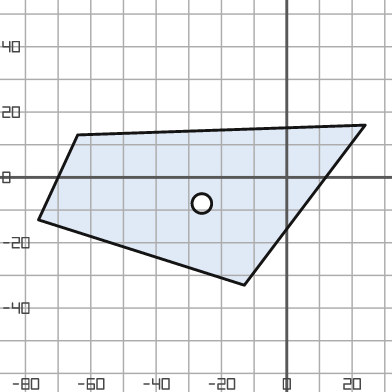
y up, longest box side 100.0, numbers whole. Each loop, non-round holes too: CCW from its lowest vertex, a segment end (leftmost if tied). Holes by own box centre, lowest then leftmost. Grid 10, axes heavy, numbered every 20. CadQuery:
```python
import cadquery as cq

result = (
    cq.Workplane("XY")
    .moveTo(-13.0, -33.0)
    .lineTo(24.0, 16.0)
    .lineTo(-64.0, 13.0)
    .lineTo(-76.0, -13.0)
    .close()
    .moveTo(-26.0, -8.0)
    .circle(3.0)
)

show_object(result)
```